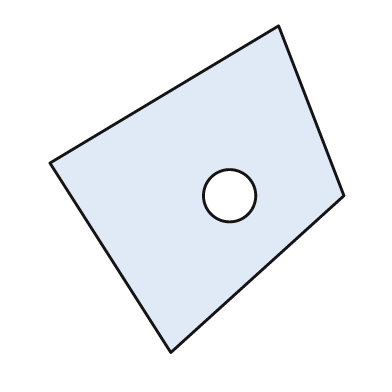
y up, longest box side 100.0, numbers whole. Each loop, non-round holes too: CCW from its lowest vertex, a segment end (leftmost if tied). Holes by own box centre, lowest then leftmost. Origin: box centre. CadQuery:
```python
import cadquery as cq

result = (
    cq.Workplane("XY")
    .moveTo(-8.0, -50.0)
    .lineTo(45.0, -2.0)
    .lineTo(25.0, 50.0)
    .lineTo(-45.0, 8.0)
    .close()
    .moveTo(10.0, -2.0)
    .circle(8.0)
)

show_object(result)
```